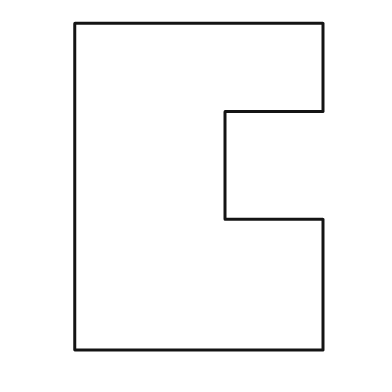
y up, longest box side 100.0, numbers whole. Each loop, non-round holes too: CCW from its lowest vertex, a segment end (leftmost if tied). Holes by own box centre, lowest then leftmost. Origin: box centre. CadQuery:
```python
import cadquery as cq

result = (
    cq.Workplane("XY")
    .moveTo(-38.0, -50.0)
    .lineTo(38.0, -50.0)
    .lineTo(38.0, -10.0)
    .lineTo(8.0, -10.0)
    .lineTo(8.0, 23.0)
    .lineTo(38.0, 23.0)
    .lineTo(38.0, 50.0)
    .lineTo(-38.0, 50.0)
    .close()
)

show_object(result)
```